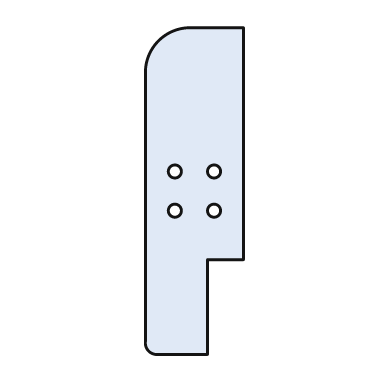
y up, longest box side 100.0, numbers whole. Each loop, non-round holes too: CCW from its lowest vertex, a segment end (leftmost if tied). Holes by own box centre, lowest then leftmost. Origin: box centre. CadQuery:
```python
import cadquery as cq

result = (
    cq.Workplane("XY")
    .moveTo(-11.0, -50.0)
    .lineTo(4.0, -50.0)
    .lineTo(4.0, -21.0)
    .lineTo(15.0, -21.0)
    .lineTo(15.0, 50.0)
    .lineTo(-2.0, 50.0)
    .threePointArc((-11.0, 46.0), (-15.0, 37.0))
    .lineTo(-15.0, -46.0)
    .threePointArc((-14.0, -49.0), (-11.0, -50.0))
    .close()
    .moveTo(-6.0, -6.0)
    .circle(2.0)
    .moveTo(6.0, -6.0)
    .circle(2.0)
    .moveTo(-6.0, 6.0)
    .circle(2.0)
    .moveTo(6.0, 6.0)
    .circle(2.0)
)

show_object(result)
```